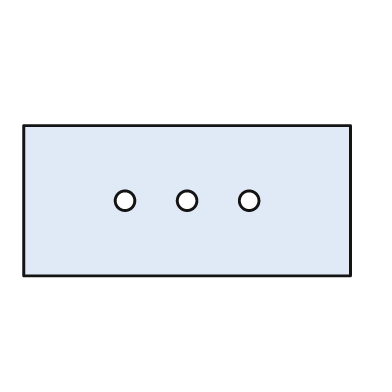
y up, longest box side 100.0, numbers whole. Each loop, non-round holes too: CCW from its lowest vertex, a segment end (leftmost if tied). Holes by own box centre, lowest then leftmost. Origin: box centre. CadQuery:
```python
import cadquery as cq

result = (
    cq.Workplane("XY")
    .moveTo(-50.0, -23.0)
    .lineTo(50.0, -23.0)
    .lineTo(50.0, 23.0)
    .lineTo(-50.0, 23.0)
    .close()
    .moveTo(-19.0, 0.0)
    .circle(3.0)
    .moveTo(0.0, 0.0)
    .circle(3.0)
    .moveTo(19.0, 0.0)
    .circle(3.0)
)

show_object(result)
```